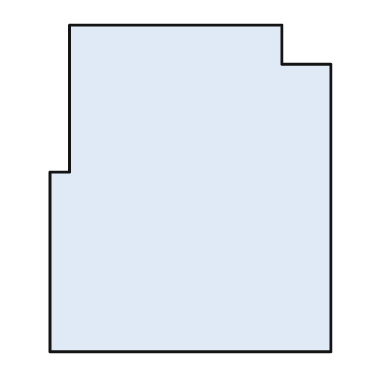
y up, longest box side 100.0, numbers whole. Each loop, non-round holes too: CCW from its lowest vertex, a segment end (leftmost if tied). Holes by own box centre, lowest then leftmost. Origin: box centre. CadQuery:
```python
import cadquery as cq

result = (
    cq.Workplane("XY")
    .moveTo(-43.0, -50.0)
    .lineTo(43.0, -50.0)
    .lineTo(43.0, 38.0)
    .lineTo(28.0, 38.0)
    .lineTo(28.0, 50.0)
    .lineTo(-37.0, 50.0)
    .lineTo(-37.0, 5.0)
    .lineTo(-43.0, 5.0)
    .close()
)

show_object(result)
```